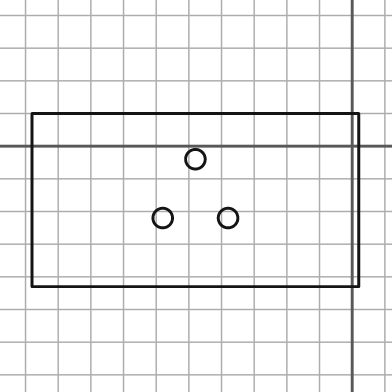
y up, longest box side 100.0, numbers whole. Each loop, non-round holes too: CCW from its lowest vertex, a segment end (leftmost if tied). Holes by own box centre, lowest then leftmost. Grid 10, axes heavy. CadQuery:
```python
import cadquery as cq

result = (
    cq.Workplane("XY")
    .moveTo(-98.0, -43.0)
    .lineTo(2.0, -43.0)
    .lineTo(2.0, 10.0)
    .lineTo(-98.0, 10.0)
    .close()
    .moveTo(-58.0, -22.0)
    .circle(3.0)
    .moveTo(-38.0, -22.0)
    .circle(3.0)
    .moveTo(-48.0, -4.0)
    .circle(3.0)
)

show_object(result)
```